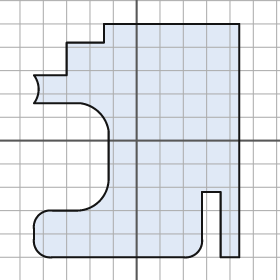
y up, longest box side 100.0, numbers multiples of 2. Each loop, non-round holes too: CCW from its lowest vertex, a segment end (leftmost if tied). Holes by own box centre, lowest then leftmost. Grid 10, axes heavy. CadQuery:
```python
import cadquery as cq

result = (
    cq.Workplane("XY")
    .moveTo(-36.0, -50.0)
    .lineTo(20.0, -50.0)
    .threePointArc((26.0, -48.0), (28.0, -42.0))
    .lineTo(28.0, -22.0)
    .lineTo(36.0, -22.0)
    .lineTo(36.0, -50.0)
    .lineTo(44.0, -50.0)
    .lineTo(44.0, 50.0)
    .lineTo(-14.0, 50.0)
    .lineTo(-14.0, 42.0)
    .lineTo(-30.0, 42.0)
    .lineTo(-30.0, 28.0)
    .lineTo(-44.0, 28.0)
    .threePointArc((-42.0, 22.0), (-44.0, 16.0))
    .lineTo(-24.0, 16.0)
    .threePointArc((-16.0, 12.0), (-12.0, 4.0))
    .lineTo(-12.0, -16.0)
    .threePointArc((-16.0, -26.0), (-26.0, -30.0))
    .lineTo(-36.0, -30.0)
    .threePointArc((-42.0, -32.0), (-44.0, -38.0))
    .lineTo(-44.0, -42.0)
    .threePointArc((-42.0, -48.0), (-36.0, -50.0))
    .close()
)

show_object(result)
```